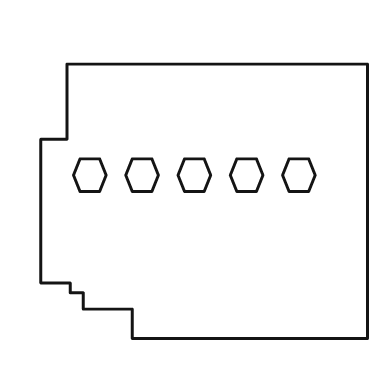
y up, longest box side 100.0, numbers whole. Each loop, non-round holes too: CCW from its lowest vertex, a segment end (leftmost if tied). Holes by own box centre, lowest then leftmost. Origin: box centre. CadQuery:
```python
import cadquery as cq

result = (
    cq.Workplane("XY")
    .moveTo(-22.0, -42.0)
    .lineTo(50.0, -42.0)
    .lineTo(50.0, 42.0)
    .lineTo(-42.0, 42.0)
    .lineTo(-42.0, 19.0)
    .lineTo(-50.0, 19.0)
    .lineTo(-50.0, -25.0)
    .lineTo(-41.0, -25.0)
    .lineTo(-41.0, -28.0)
    .lineTo(-37.0, -28.0)
    .lineTo(-37.0, -33.0)
    .lineTo(-22.0, -33.0)
    .close()
    .moveTo(-38.0, 3.0)
    .lineTo(-32.0, 3.0)
    .lineTo(-30.0, 8.0)
    .lineTo(-32.0, 13.0)
    .lineTo(-38.0, 13.0)
    .lineTo(-40.0, 8.0)
    .close()
    .moveTo(-22.0, 3.0)
    .lineTo(-16.0, 3.0)
    .lineTo(-14.0, 8.0)
    .lineTo(-16.0, 13.0)
    .lineTo(-22.0, 13.0)
    .lineTo(-24.0, 8.0)
    .close()
    .moveTo(-6.0, 3.0)
    .lineTo(0.0, 3.0)
    .lineTo(2.0, 8.0)
    .lineTo(0.0, 13.0)
    .lineTo(-6.0, 13.0)
    .lineTo(-8.0, 8.0)
    .close()
    .moveTo(10.0, 3.0)
    .lineTo(16.0, 3.0)
    .lineTo(18.0, 8.0)
    .lineTo(16.0, 13.0)
    .lineTo(10.0, 13.0)
    .lineTo(8.0, 8.0)
    .close()
    .moveTo(26.0, 3.0)
    .lineTo(32.0, 3.0)
    .lineTo(34.0, 8.0)
    .lineTo(32.0, 13.0)
    .lineTo(26.0, 13.0)
    .lineTo(24.0, 8.0)
    .close()
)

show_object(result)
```